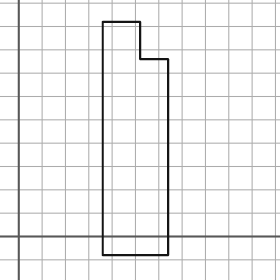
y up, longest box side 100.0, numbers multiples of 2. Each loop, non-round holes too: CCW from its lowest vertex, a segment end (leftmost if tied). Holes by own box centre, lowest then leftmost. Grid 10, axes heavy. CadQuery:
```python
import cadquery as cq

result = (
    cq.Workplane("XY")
    .moveTo(36.0, -8.0)
    .lineTo(64.0, -8.0)
    .lineTo(64.0, 76.0)
    .lineTo(52.0, 76.0)
    .lineTo(52.0, 92.0)
    .lineTo(36.0, 92.0)
    .close()
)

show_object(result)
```